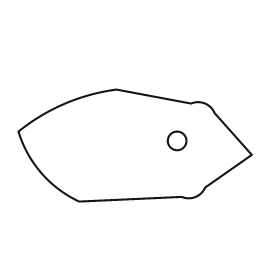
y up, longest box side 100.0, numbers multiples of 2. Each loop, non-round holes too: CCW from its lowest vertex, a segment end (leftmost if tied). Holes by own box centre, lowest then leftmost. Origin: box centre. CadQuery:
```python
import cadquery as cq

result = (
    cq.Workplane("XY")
    .moveTo(-24.0, -24.0)
    .lineTo(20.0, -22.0)
    .threePointArc((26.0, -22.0), (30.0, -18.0))
    .lineTo(50.0, -4.0)
    .lineTo(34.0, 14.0)
    .threePointArc((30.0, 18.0), (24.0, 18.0))
    .lineTo(-8.0, 24.0)
    .threePointArc((-30.0, 18.0), (-50.0, 6.0))
    .threePointArc((-40.0, -12.0), (-24.0, -24.0))
    .close()
    .moveTo(18.0, 2.0)
    .circle(4.0)
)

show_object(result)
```